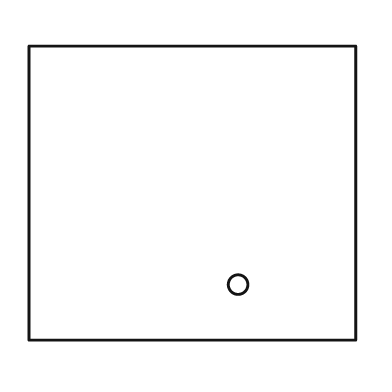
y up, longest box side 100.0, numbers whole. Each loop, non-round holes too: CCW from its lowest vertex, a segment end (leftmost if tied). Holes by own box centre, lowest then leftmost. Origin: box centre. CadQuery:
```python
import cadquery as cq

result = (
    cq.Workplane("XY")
    .moveTo(-50.0, -45.0)
    .lineTo(50.0, -45.0)
    .lineTo(50.0, 45.0)
    .lineTo(-50.0, 45.0)
    .close()
    .moveTo(14.0, -28.0)
    .circle(3.0)
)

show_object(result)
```